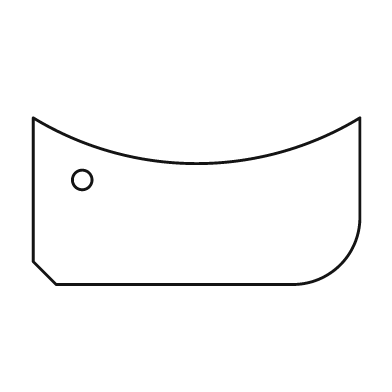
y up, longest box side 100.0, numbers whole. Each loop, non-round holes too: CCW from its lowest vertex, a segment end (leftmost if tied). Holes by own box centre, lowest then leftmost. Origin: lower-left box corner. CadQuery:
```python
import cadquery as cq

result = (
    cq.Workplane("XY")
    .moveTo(7.0, 0.0)
    .lineTo(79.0, 0.0)
    .threePointArc((94.0, 6.0), (100.0, 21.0))
    .lineTo(100.0, 51.0)
    .threePointArc((50.0, 37.0), (0.0, 51.0))
    .lineTo(0.0, 7.0)
    .close()
    .moveTo(15.0, 32.0)
    .circle(3.0)
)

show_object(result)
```